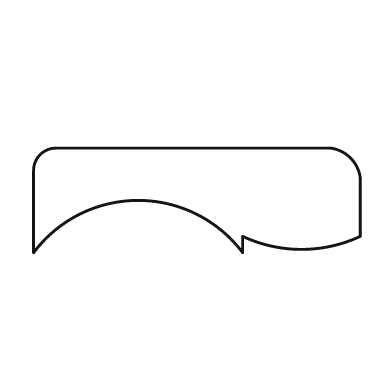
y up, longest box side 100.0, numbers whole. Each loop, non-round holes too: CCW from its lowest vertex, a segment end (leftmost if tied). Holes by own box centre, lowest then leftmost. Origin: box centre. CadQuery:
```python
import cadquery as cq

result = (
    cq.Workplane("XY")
    .moveTo(-50.0, -16.0)
    .threePointArc((-18.0, 0.0), (14.0, -16.0))
    .lineTo(14.0, -11.0)
    .threePointArc((32.0, -15.0), (50.0, -11.0))
    .lineTo(50.0, 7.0)
    .threePointArc((47.0, 13.0), (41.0, 16.0))
    .lineTo(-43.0, 16.0)
    .threePointArc((-48.0, 14.0), (-50.0, 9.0))
    .close()
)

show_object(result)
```